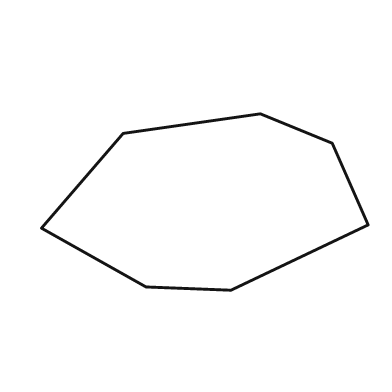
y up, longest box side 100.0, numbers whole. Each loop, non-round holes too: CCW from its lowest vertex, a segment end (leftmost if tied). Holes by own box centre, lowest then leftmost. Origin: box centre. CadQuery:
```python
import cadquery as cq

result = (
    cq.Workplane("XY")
    .moveTo(8.0, -27.0)
    .lineTo(50.0, -7.0)
    .lineTo(39.0, 18.0)
    .lineTo(17.0, 27.0)
    .lineTo(-25.0, 21.0)
    .lineTo(-50.0, -8.0)
    .lineTo(-18.0, -26.0)
    .close()
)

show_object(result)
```